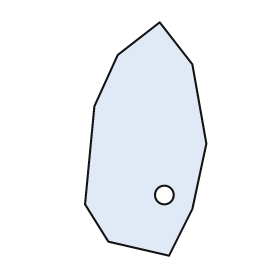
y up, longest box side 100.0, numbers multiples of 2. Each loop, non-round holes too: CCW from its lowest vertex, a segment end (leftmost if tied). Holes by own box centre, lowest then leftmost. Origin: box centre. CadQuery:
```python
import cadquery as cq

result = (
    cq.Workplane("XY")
    .moveTo(10.0, -50.0)
    .lineTo(20.0, -30.0)
    .lineTo(26.0, -2.0)
    .lineTo(20.0, 32.0)
    .lineTo(6.0, 50.0)
    .lineTo(-12.0, 36.0)
    .lineTo(-22.0, 14.0)
    .lineTo(-26.0, -28.0)
    .lineTo(-16.0, -44.0)
    .close()
    .moveTo(8.0, -24.0)
    .circle(4.0)
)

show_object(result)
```